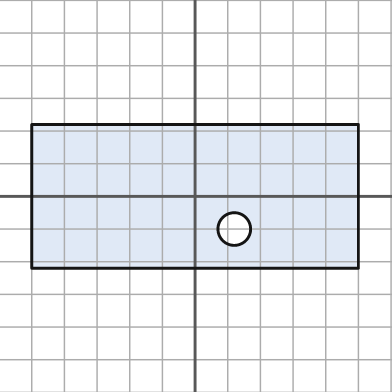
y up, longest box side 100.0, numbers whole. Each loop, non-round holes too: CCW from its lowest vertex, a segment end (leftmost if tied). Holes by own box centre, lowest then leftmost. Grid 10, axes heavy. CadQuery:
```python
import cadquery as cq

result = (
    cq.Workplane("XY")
    .moveTo(-50.0, -22.0)
    .lineTo(50.0, -22.0)
    .lineTo(50.0, 22.0)
    .lineTo(-50.0, 22.0)
    .close()
    .moveTo(12.0, -10.0)
    .circle(5.0)
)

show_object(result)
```